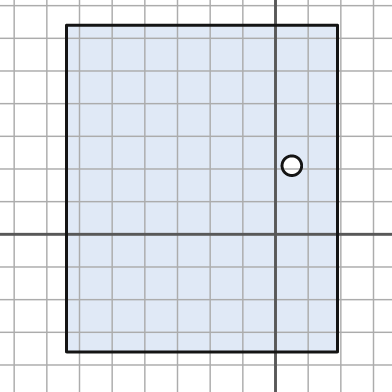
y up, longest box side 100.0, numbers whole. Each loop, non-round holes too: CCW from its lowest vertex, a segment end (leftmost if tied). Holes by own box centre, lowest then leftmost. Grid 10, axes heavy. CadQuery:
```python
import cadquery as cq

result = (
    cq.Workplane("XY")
    .moveTo(-64.0, -36.0)
    .lineTo(19.0, -36.0)
    .lineTo(19.0, 64.0)
    .lineTo(-64.0, 64.0)
    .close()
    .moveTo(5.0, 21.0)
    .circle(3.0)
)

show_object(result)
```